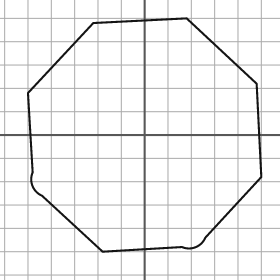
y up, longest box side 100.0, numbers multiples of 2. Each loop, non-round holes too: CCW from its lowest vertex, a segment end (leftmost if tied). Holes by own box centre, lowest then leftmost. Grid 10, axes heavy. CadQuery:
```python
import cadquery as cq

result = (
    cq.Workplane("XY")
    .moveTo(-18.0, -50.0)
    .lineTo(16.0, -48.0)
    .threePointArc((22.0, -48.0), (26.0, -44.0))
    .lineTo(50.0, -18.0)
    .lineTo(48.0, 22.0)
    .lineTo(18.0, 50.0)
    .lineTo(-22.0, 48.0)
    .lineTo(-50.0, 18.0)
    .lineTo(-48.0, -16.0)
    .threePointArc((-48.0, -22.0), (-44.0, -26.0))
    .close()
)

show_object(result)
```